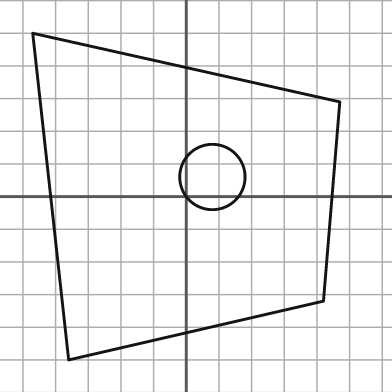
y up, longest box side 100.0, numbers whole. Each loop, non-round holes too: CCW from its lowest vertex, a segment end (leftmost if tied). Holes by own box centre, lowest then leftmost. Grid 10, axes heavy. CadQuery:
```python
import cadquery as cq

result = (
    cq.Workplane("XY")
    .moveTo(-36.0, -50.0)
    .lineTo(42.0, -32.0)
    .lineTo(47.0, 29.0)
    .lineTo(-47.0, 50.0)
    .close()
    .moveTo(8.0, 6.0)
    .circle(10.0)
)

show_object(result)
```